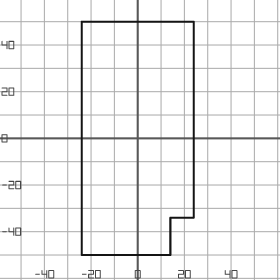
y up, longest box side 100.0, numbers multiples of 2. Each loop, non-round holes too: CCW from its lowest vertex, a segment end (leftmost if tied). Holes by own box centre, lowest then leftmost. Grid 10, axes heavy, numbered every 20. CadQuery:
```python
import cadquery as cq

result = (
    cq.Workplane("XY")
    .moveTo(-24.0, -50.0)
    .lineTo(14.0, -50.0)
    .lineTo(14.0, -34.0)
    .lineTo(24.0, -34.0)
    .lineTo(24.0, 50.0)
    .lineTo(-24.0, 50.0)
    .close()
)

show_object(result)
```